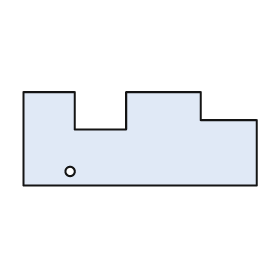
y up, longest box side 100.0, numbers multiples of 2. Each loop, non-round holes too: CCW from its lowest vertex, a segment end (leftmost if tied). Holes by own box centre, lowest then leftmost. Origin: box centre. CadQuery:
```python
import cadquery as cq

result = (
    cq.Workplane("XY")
    .moveTo(-50.0, -20.0)
    .lineTo(50.0, -20.0)
    .lineTo(50.0, 8.0)
    .lineTo(26.0, 8.0)
    .lineTo(26.0, 20.0)
    .lineTo(-6.0, 20.0)
    .lineTo(-6.0, 4.0)
    .lineTo(-28.0, 4.0)
    .lineTo(-28.0, 20.0)
    .lineTo(-50.0, 20.0)
    .close()
    .moveTo(-30.0, -14.0)
    .circle(2.0)
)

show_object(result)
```